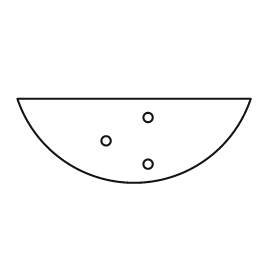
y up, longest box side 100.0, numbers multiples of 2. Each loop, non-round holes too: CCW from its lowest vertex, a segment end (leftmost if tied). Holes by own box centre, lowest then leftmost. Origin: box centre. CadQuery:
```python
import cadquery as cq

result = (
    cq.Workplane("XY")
    .moveTo(-50.0, 18.0)
    .threePointArc((0.0, -18.0), (50.0, 18.0))
    .close()
    .moveTo(6.0, -10.0)
    .circle(2.0)
    .moveTo(-12.0, 0.0)
    .circle(2.0)
    .moveTo(6.0, 10.0)
    .circle(2.0)
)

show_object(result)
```